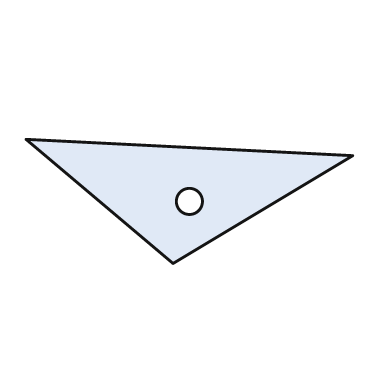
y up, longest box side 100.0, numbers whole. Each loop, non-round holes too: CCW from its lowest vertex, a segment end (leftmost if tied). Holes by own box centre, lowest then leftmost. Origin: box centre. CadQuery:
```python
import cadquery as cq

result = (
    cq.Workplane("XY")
    .moveTo(-5.0, -19.0)
    .lineTo(50.0, 14.0)
    .lineTo(-50.0, 19.0)
    .close()
    .moveTo(0.0, 0.0)
    .circle(4.0)
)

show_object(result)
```